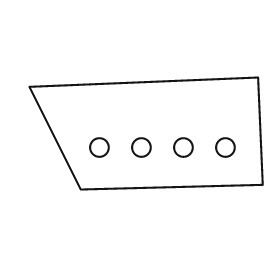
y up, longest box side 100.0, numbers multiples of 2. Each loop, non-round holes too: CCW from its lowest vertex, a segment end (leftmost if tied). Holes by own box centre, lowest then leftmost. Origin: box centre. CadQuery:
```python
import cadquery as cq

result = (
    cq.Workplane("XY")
    .moveTo(-28.0, -24.0)
    .lineTo(50.0, -22.0)
    .lineTo(48.0, 24.0)
    .lineTo(-50.0, 20.0)
    .close()
    .moveTo(-20.0, -6.0)
    .circle(4.0)
    .moveTo(-2.0, -6.0)
    .circle(4.0)
    .moveTo(16.0, -6.0)
    .circle(4.0)
    .moveTo(34.0, -6.0)
    .circle(4.0)
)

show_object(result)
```